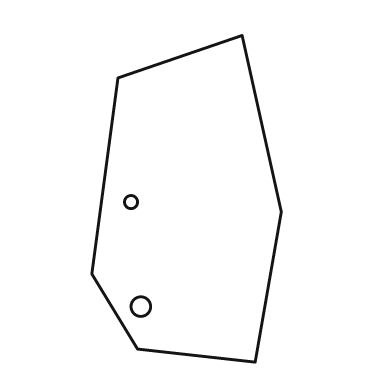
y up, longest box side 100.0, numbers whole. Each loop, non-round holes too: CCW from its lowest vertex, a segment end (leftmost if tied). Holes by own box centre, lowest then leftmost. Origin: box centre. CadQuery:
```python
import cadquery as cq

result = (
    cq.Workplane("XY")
    .moveTo(21.0, -50.0)
    .lineTo(29.0, -4.0)
    .lineTo(17.0, 50.0)
    .lineTo(-21.0, 37.0)
    .lineTo(-29.0, -23.0)
    .lineTo(-15.0, -46.0)
    .close()
    .moveTo(-14.0, -33.0)
    .circle(3.0)
    .moveTo(-17.0, -1.0)
    .circle(2.0)
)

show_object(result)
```